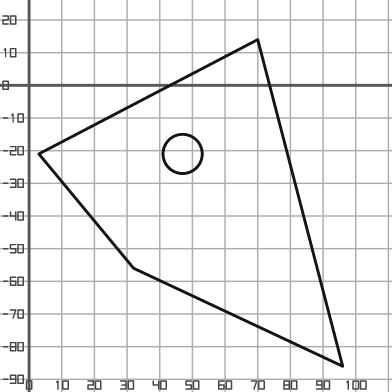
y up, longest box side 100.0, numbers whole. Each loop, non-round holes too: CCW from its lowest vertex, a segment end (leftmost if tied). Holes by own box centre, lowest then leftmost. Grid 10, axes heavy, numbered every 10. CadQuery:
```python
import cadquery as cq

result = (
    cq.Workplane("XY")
    .moveTo(96.0, -86.0)
    .lineTo(70.0, 14.0)
    .lineTo(3.0, -21.0)
    .lineTo(32.0, -56.0)
    .close()
    .moveTo(47.0, -21.0)
    .circle(6.0)
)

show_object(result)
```